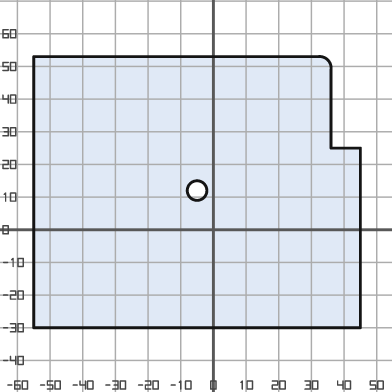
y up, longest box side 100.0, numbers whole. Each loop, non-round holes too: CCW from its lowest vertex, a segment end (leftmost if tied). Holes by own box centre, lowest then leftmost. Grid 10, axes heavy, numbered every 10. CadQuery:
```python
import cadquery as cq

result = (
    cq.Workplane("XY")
    .moveTo(-55.0, -30.0)
    .lineTo(45.0, -30.0)
    .lineTo(45.0, 25.0)
    .lineTo(36.0, 25.0)
    .lineTo(36.0, 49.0)
    .threePointArc((35.0, 52.0), (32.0, 53.0))
    .lineTo(-55.0, 53.0)
    .close()
    .moveTo(-5.0, 12.0)
    .circle(3.0)
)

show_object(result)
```